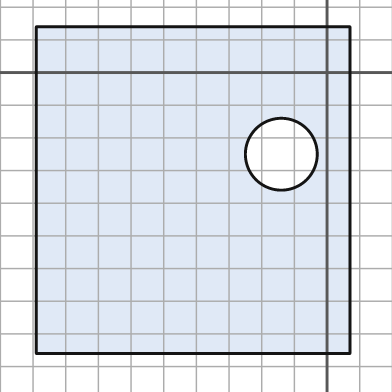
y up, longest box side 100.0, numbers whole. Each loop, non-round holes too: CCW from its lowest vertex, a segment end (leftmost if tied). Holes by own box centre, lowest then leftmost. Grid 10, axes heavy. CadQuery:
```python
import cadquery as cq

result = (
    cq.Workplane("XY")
    .moveTo(-89.0, -86.0)
    .lineTo(7.0, -86.0)
    .lineTo(7.0, 14.0)
    .lineTo(-89.0, 14.0)
    .close()
    .moveTo(-14.0, -25.0)
    .circle(11.0)
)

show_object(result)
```